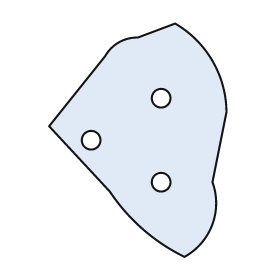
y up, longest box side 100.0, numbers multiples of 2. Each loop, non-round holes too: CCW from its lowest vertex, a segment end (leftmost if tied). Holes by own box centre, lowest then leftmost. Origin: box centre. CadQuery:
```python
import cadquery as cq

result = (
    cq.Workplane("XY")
    .moveTo(20.0, -50.0)
    .threePointArc((32.0, -36.0), (32.0, -18.0))
    .lineTo(38.0, 12.0)
    .threePointArc((32.0, 34.0), (16.0, 50.0))
    .lineTo(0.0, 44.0)
    .threePointArc((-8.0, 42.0), (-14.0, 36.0))
    .lineTo(-38.0, 6.0)
    .lineTo(-12.0, -22.0)
    .threePointArc((2.0, -38.0), (20.0, -50.0))
    .close()
    .moveTo(10.0, -18.0)
    .circle(4.0)
    .moveTo(-20.0, 0.0)
    .circle(4.0)
    .moveTo(10.0, 18.0)
    .circle(4.0)
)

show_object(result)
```